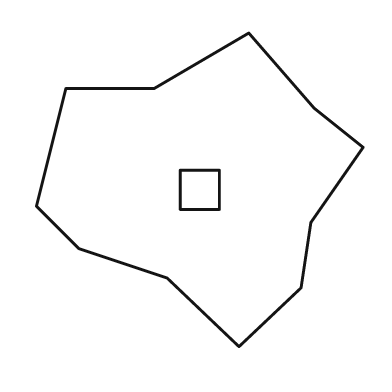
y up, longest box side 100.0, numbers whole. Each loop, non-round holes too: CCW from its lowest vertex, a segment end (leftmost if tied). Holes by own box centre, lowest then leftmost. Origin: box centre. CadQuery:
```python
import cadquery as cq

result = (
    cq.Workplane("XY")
    .moveTo(12.0, -48.0)
    .lineTo(31.0, -30.0)
    .lineTo(34.0, -10.0)
    .lineTo(50.0, 13.0)
    .lineTo(35.0, 25.0)
    .lineTo(15.0, 48.0)
    .lineTo(-14.0, 31.0)
    .lineTo(-41.0, 31.0)
    .lineTo(-50.0, -5.0)
    .lineTo(-37.0, -18.0)
    .lineTo(-10.0, -27.0)
    .close()
    .moveTo(-6.0, -6.0)
    .lineTo(6.0, -6.0)
    .lineTo(6.0, 6.0)
    .lineTo(-6.0, 6.0)
    .close()
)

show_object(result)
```